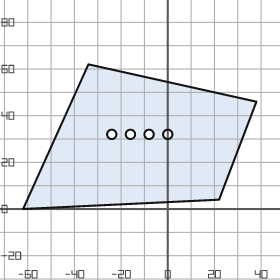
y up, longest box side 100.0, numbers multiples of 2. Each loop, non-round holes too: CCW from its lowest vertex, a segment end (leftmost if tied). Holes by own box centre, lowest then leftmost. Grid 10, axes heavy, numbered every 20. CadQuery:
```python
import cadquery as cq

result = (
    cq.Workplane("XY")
    .moveTo(-62.0, 0.0)
    .lineTo(22.0, 4.0)
    .lineTo(38.0, 46.0)
    .lineTo(-34.0, 62.0)
    .close()
    .moveTo(-24.0, 32.0)
    .circle(2.0)
    .moveTo(-16.0, 32.0)
    .circle(2.0)
    .moveTo(-8.0, 32.0)
    .circle(2.0)
    .moveTo(0.0, 32.0)
    .circle(2.0)
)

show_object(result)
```